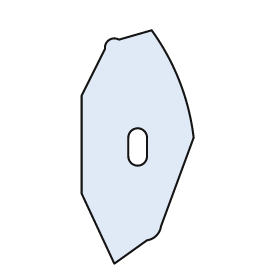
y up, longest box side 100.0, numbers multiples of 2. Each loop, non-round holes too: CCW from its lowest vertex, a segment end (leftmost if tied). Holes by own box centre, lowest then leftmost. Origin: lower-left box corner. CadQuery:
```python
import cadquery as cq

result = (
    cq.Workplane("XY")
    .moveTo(14.0, 0.0)
    .lineTo(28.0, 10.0)
    .threePointArc((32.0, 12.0), (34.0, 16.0))
    .lineTo(48.0, 54.0)
    .threePointArc((42.0, 78.0), (30.0, 100.0))
    .lineTo(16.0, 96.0)
    .threePointArc((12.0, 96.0), (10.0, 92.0))
    .lineTo(0.0, 72.0)
    .lineTo(0.0, 30.0)
    .close()
    .moveTo(20.0, 46.0)
    .threePointArc((24.0, 42.0), (28.0, 46.0))
    .lineTo(28.0, 54.0)
    .threePointArc((24.0, 58.0), (20.0, 54.0))
    .close()
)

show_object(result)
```